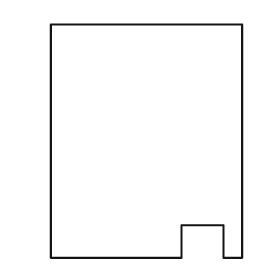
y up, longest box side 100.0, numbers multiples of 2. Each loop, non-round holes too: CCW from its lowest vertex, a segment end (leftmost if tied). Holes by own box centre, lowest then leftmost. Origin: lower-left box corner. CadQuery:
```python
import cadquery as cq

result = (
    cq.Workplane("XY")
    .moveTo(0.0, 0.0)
    .lineTo(56.0, 0.0)
    .lineTo(56.0, 14.0)
    .lineTo(74.0, 14.0)
    .lineTo(74.0, 0.0)
    .lineTo(82.0, 0.0)
    .lineTo(82.0, 100.0)
    .lineTo(0.0, 100.0)
    .close()
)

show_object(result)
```